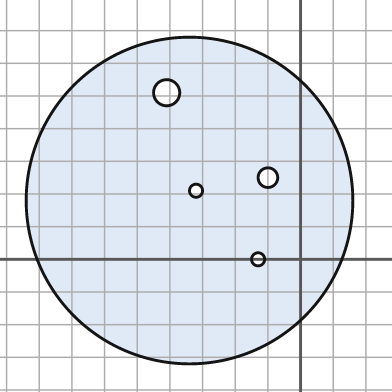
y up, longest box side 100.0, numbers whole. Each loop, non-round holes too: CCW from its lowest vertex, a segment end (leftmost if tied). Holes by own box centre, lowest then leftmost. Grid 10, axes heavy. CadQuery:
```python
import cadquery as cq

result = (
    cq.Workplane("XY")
    .moveTo(-34.0, 18.0)
    .circle(50.0)
    .moveTo(-13.0, 0.0)
    .circle(2.0)
    .moveTo(-32.0, 21.0)
    .circle(2.0)
    .moveTo(-10.0, 25.0)
    .circle(3.0)
    .moveTo(-41.0, 51.0)
    .circle(4.0)
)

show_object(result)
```